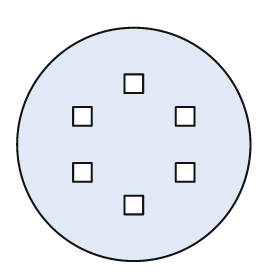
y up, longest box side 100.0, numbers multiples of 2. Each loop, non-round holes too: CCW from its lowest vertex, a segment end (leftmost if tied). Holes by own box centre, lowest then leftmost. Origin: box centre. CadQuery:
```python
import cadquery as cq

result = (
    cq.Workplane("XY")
    .moveTo(0.0, 0.0)
    .circle(50.0)
    .moveTo(-4.0, -30.0)
    .lineTo(4.0, -30.0)
    .lineTo(4.0, -22.0)
    .lineTo(-4.0, -22.0)
    .close()
    .moveTo(-26.0, -16.0)
    .lineTo(-18.0, -16.0)
    .lineTo(-18.0, -8.0)
    .lineTo(-26.0, -8.0)
    .close()
    .moveTo(18.0, -16.0)
    .lineTo(26.0, -16.0)
    .lineTo(26.0, -8.0)
    .lineTo(18.0, -8.0)
    .close()
    .moveTo(-26.0, 8.0)
    .lineTo(-18.0, 8.0)
    .lineTo(-18.0, 16.0)
    .lineTo(-26.0, 16.0)
    .close()
    .moveTo(18.0, 8.0)
    .lineTo(26.0, 8.0)
    .lineTo(26.0, 16.0)
    .lineTo(18.0, 16.0)
    .close()
    .moveTo(-4.0, 22.0)
    .lineTo(4.0, 22.0)
    .lineTo(4.0, 30.0)
    .lineTo(-4.0, 30.0)
    .close()
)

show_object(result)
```